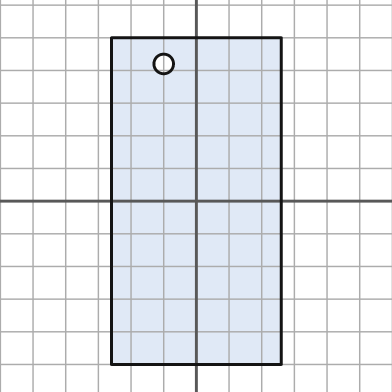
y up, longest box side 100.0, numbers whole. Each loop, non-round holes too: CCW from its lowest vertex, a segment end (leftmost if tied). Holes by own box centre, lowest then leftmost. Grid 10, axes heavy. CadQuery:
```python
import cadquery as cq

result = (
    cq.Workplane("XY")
    .moveTo(-26.0, -50.0)
    .lineTo(26.0, -50.0)
    .lineTo(26.0, 50.0)
    .lineTo(-26.0, 50.0)
    .close()
    .moveTo(-10.0, 42.0)
    .circle(3.0)
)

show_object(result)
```